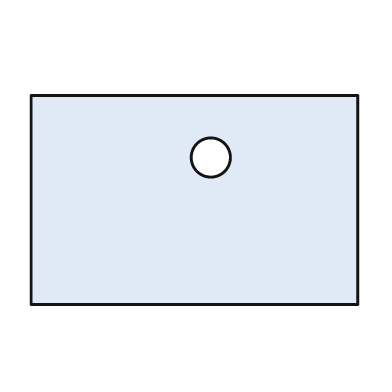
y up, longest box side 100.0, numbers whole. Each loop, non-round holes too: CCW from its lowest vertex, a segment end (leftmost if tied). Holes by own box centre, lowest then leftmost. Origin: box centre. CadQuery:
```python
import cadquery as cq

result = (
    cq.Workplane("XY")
    .moveTo(-50.0, -32.0)
    .lineTo(50.0, -32.0)
    .lineTo(50.0, 32.0)
    .lineTo(-50.0, 32.0)
    .close()
    .moveTo(5.0, 13.0)
    .circle(6.0)
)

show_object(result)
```